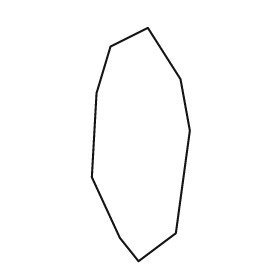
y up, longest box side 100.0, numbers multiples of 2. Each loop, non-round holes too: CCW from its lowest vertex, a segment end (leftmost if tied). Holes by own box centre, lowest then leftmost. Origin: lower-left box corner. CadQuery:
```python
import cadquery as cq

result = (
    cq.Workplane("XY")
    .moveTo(20.0, 0.0)
    .lineTo(36.0, 12.0)
    .lineTo(42.0, 56.0)
    .lineTo(38.0, 78.0)
    .lineTo(24.0, 100.0)
    .lineTo(8.0, 92.0)
    .lineTo(2.0, 72.0)
    .lineTo(0.0, 36.0)
    .lineTo(12.0, 10.0)
    .close()
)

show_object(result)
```